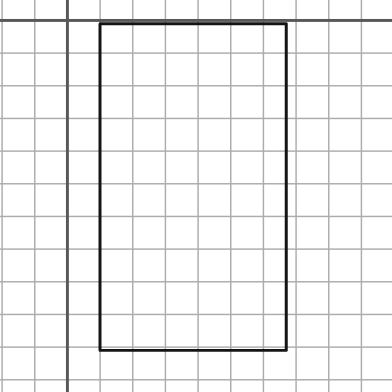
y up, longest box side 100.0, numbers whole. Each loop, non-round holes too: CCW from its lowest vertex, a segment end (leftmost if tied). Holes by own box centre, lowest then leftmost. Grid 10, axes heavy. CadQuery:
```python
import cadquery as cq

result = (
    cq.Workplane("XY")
    .moveTo(10.0, -101.0)
    .lineTo(67.0, -101.0)
    .lineTo(67.0, -1.0)
    .lineTo(10.0, -1.0)
    .close()
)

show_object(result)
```